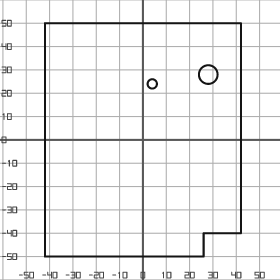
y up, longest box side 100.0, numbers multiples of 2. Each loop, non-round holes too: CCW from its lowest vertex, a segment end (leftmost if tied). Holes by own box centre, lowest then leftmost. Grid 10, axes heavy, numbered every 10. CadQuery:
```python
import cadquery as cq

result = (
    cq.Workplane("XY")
    .moveTo(-42.0, -50.0)
    .lineTo(26.0, -50.0)
    .lineTo(26.0, -40.0)
    .lineTo(42.0, -40.0)
    .lineTo(42.0, 50.0)
    .lineTo(-42.0, 50.0)
    .close()
    .moveTo(4.0, 24.0)
    .circle(2.0)
    .moveTo(28.0, 28.0)
    .circle(4.0)
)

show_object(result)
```